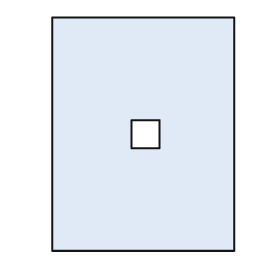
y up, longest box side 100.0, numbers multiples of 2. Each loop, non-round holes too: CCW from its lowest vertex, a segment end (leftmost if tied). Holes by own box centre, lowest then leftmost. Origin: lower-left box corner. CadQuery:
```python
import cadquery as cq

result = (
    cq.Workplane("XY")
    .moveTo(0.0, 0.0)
    .lineTo(78.0, 0.0)
    .lineTo(78.0, 100.0)
    .lineTo(0.0, 100.0)
    .close()
    .moveTo(34.0, 44.0)
    .lineTo(46.0, 44.0)
    .lineTo(46.0, 56.0)
    .lineTo(34.0, 56.0)
    .close()
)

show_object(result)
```